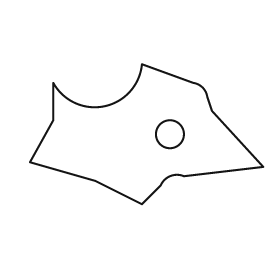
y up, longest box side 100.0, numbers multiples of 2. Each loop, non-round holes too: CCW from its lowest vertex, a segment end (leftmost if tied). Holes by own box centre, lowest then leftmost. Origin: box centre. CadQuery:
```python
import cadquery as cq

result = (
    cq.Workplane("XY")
    .moveTo(-2.0, -30.0)
    .lineTo(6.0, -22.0)
    .threePointArc((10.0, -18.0), (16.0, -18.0))
    .lineTo(50.0, -14.0)
    .lineTo(28.0, 10.0)
    .lineTo(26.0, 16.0)
    .threePointArc((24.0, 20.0), (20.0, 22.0))
    .lineTo(-2.0, 30.0)
    .threePointArc((-18.0, 12.0), (-40.0, 22.0))
    .lineTo(-40.0, 6.0)
    .lineTo(-50.0, -12.0)
    .lineTo(-22.0, -20.0)
    .close()
    .moveTo(10.0, 0.0)
    .circle(6.0)
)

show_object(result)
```